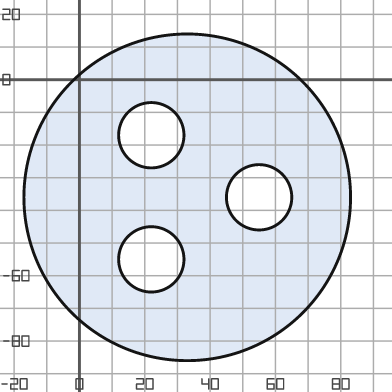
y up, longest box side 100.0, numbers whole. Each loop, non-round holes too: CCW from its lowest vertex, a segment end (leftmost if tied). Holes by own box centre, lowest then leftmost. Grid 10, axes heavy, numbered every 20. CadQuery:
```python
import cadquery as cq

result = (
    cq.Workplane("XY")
    .moveTo(33.0, -36.0)
    .circle(50.0)
    .moveTo(22.0, -55.0)
    .circle(10.0)
    .moveTo(55.0, -36.0)
    .circle(10.0)
    .moveTo(22.0, -17.0)
    .circle(10.0)
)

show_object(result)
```